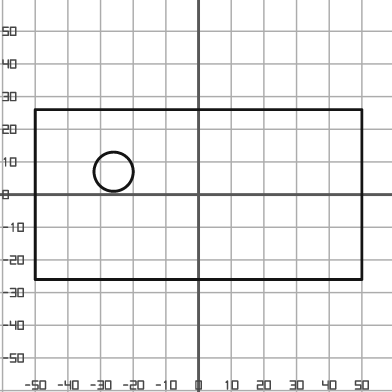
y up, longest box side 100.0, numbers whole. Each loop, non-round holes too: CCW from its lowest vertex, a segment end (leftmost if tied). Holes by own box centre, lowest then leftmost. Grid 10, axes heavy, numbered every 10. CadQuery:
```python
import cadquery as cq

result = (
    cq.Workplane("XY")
    .moveTo(-50.0, -26.0)
    .lineTo(50.0, -26.0)
    .lineTo(50.0, 26.0)
    .lineTo(-50.0, 26.0)
    .close()
    .moveTo(-26.0, 7.0)
    .circle(6.0)
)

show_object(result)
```